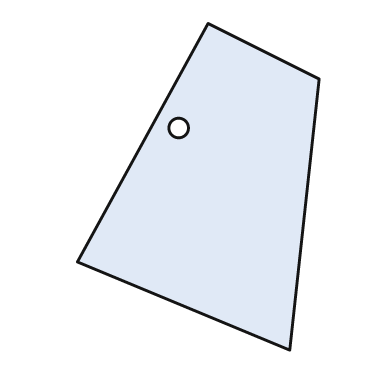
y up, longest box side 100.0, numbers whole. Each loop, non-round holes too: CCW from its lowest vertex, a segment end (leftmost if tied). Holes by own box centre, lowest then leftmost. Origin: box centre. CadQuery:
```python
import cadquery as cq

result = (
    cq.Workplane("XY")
    .moveTo(28.0, -50.0)
    .lineTo(37.0, 33.0)
    .lineTo(3.0, 50.0)
    .lineTo(-37.0, -23.0)
    .close()
    .moveTo(-6.0, 18.0)
    .circle(3.0)
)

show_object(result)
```